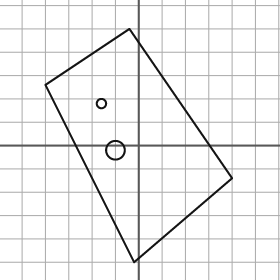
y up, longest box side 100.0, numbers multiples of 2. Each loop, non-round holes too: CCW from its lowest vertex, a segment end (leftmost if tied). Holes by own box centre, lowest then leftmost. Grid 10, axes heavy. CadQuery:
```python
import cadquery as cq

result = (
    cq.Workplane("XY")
    .moveTo(-2.0, -50.0)
    .lineTo(40.0, -14.0)
    .lineTo(-4.0, 50.0)
    .lineTo(-40.0, 26.0)
    .close()
    .moveTo(-10.0, -2.0)
    .circle(4.0)
    .moveTo(-16.0, 18.0)
    .circle(2.0)
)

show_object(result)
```